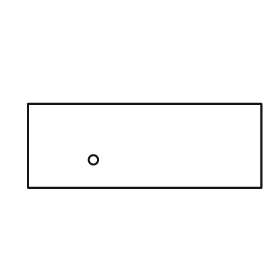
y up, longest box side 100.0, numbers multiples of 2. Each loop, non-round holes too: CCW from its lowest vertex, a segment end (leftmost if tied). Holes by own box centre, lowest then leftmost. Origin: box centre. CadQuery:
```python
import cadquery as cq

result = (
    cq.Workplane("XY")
    .moveTo(-50.0, -18.0)
    .lineTo(50.0, -18.0)
    .lineTo(50.0, 18.0)
    .lineTo(-50.0, 18.0)
    .close()
    .moveTo(-22.0, -6.0)
    .circle(2.0)
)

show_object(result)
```